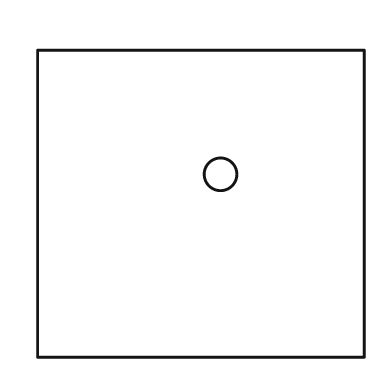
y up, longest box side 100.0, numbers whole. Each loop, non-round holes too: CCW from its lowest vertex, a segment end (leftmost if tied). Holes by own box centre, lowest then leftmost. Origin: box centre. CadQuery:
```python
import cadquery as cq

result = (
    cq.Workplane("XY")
    .moveTo(-50.0, -47.0)
    .lineTo(50.0, -47.0)
    .lineTo(50.0, 47.0)
    .lineTo(-50.0, 47.0)
    .close()
    .moveTo(6.0, 9.0)
    .circle(5.0)
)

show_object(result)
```